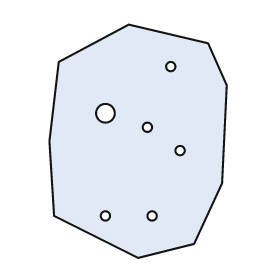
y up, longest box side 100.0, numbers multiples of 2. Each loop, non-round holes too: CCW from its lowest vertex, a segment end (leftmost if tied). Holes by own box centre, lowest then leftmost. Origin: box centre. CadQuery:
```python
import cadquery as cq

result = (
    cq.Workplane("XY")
    .moveTo(0.0, -50.0)
    .lineTo(24.0, -44.0)
    .lineTo(36.0, -18.0)
    .lineTo(38.0, 24.0)
    .lineTo(30.0, 42.0)
    .lineTo(-4.0, 50.0)
    .lineTo(-34.0, 34.0)
    .lineTo(-38.0, 0.0)
    .lineTo(-36.0, -32.0)
    .close()
    .moveTo(-14.0, -32.0)
    .circle(2.0)
    .moveTo(6.0, -32.0)
    .circle(2.0)
    .moveTo(18.0, -4.0)
    .circle(2.0)
    .moveTo(4.0, 6.0)
    .circle(2.0)
    .moveTo(-14.0, 12.0)
    .circle(4.0)
    .moveTo(14.0, 32.0)
    .circle(2.0)
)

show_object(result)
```